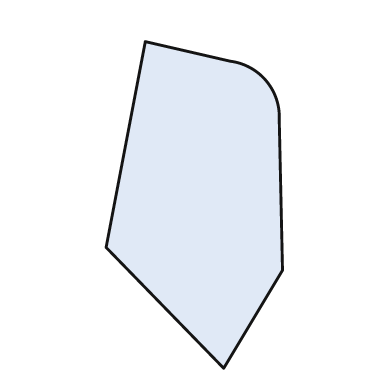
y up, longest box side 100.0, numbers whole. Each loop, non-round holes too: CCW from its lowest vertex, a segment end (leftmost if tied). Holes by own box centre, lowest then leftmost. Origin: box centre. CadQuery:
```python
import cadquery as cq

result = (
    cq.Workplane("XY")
    .moveTo(9.0, -50.0)
    .lineTo(27.0, -20.0)
    .lineTo(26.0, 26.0)
    .threePointArc((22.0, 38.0), (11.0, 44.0))
    .lineTo(-15.0, 50.0)
    .lineTo(-27.0, -13.0)
    .close()
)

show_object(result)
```